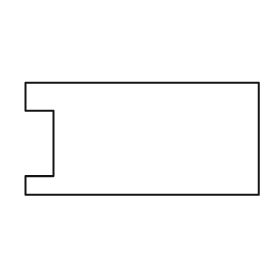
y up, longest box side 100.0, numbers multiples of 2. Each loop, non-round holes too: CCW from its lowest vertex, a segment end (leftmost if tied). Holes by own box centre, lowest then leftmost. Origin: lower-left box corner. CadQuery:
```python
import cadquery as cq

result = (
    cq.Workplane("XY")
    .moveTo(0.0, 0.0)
    .lineTo(100.0, 0.0)
    .lineTo(100.0, 48.0)
    .lineTo(0.0, 48.0)
    .lineTo(0.0, 36.0)
    .lineTo(12.0, 36.0)
    .lineTo(12.0, 8.0)
    .lineTo(0.0, 8.0)
    .close()
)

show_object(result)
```